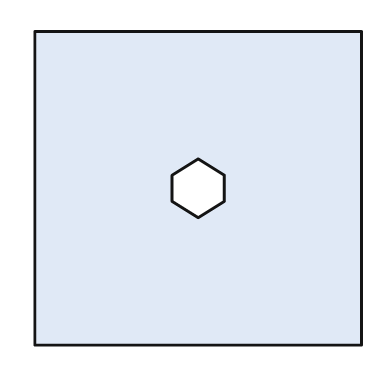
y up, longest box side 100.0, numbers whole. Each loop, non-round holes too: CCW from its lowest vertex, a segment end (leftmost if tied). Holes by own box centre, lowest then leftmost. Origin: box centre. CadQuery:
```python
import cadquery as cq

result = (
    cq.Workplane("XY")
    .moveTo(-50.0, -48.0)
    .lineTo(50.0, -48.0)
    .lineTo(50.0, 48.0)
    .lineTo(-50.0, 48.0)
    .close()
    .moveTo(0.0, -9.0)
    .lineTo(8.0, -4.0)
    .lineTo(8.0, 4.0)
    .lineTo(0.0, 9.0)
    .lineTo(-8.0, 4.0)
    .lineTo(-8.0, -4.0)
    .close()
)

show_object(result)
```